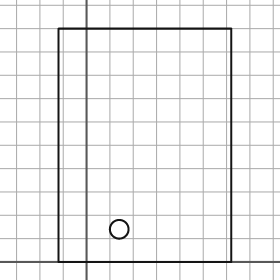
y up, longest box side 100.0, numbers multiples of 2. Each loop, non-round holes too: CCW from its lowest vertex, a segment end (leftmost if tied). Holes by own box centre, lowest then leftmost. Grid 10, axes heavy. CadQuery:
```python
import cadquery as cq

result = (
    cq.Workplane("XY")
    .moveTo(-12.0, 0.0)
    .lineTo(62.0, 0.0)
    .lineTo(62.0, 100.0)
    .lineTo(-12.0, 100.0)
    .close()
    .moveTo(14.0, 14.0)
    .circle(4.0)
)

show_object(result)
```